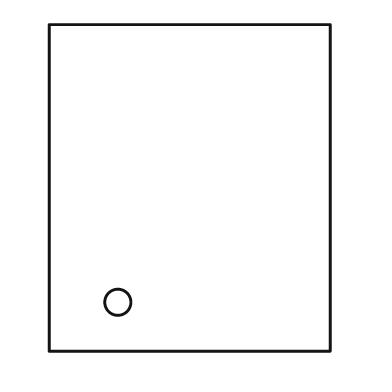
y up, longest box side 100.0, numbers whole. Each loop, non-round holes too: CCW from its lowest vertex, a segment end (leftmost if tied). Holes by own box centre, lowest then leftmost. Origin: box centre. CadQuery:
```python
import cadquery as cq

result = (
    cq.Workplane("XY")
    .moveTo(-43.0, -50.0)
    .lineTo(43.0, -50.0)
    .lineTo(43.0, 50.0)
    .lineTo(-43.0, 50.0)
    .close()
    .moveTo(-22.0, -35.0)
    .circle(4.0)
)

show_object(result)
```